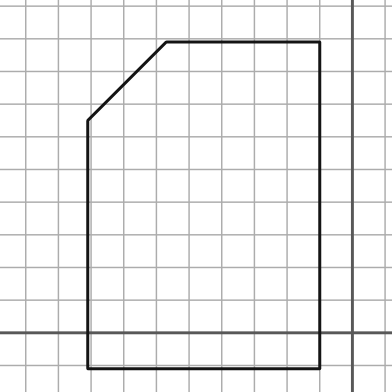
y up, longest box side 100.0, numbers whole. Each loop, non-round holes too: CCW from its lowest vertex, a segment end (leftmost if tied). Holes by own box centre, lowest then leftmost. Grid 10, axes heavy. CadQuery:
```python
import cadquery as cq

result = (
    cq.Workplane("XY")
    .moveTo(-81.0, -11.0)
    .lineTo(-10.0, -11.0)
    .lineTo(-10.0, 89.0)
    .lineTo(-57.0, 89.0)
    .lineTo(-81.0, 65.0)
    .close()
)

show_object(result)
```